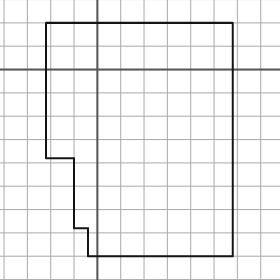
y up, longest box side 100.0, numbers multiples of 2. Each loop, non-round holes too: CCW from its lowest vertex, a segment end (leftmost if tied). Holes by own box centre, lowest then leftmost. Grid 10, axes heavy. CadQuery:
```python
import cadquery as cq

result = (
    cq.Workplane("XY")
    .moveTo(-4.0, -80.0)
    .lineTo(58.0, -80.0)
    .lineTo(58.0, 20.0)
    .lineTo(-22.0, 20.0)
    .lineTo(-22.0, -38.0)
    .lineTo(-10.0, -38.0)
    .lineTo(-10.0, -68.0)
    .lineTo(-4.0, -68.0)
    .close()
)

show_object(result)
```